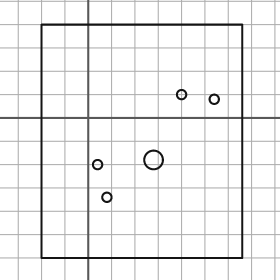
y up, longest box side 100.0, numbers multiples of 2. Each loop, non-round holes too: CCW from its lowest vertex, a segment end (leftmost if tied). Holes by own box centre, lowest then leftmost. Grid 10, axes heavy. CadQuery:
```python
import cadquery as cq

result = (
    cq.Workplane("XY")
    .moveTo(-20.0, -60.0)
    .lineTo(66.0, -60.0)
    .lineTo(66.0, 40.0)
    .lineTo(-20.0, 40.0)
    .close()
    .moveTo(8.0, -34.0)
    .circle(2.0)
    .moveTo(4.0, -20.0)
    .circle(2.0)
    .moveTo(28.0, -18.0)
    .circle(4.0)
    .moveTo(54.0, 8.0)
    .circle(2.0)
    .moveTo(40.0, 10.0)
    .circle(2.0)
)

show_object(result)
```